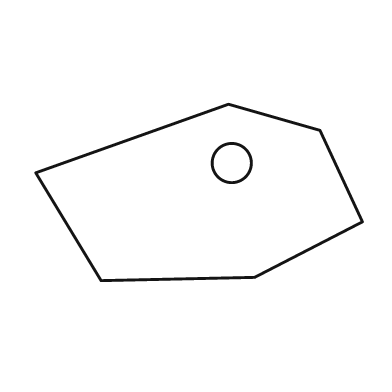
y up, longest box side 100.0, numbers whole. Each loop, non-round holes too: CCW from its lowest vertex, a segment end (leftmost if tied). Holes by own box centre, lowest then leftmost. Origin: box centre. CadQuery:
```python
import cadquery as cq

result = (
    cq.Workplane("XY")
    .moveTo(-30.0, -27.0)
    .lineTo(17.0, -26.0)
    .lineTo(50.0, -9.0)
    .lineTo(37.0, 19.0)
    .lineTo(9.0, 27.0)
    .lineTo(-50.0, 6.0)
    .close()
    .moveTo(10.0, 9.0)
    .circle(6.0)
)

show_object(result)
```